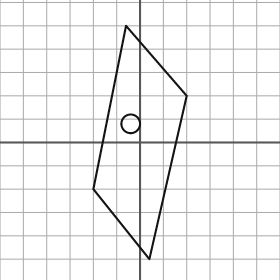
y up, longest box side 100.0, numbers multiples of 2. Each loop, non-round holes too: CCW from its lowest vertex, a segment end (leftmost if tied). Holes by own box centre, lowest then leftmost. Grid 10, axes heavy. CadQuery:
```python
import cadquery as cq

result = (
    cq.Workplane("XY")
    .moveTo(4.0, -50.0)
    .lineTo(20.0, 20.0)
    .lineTo(-6.0, 50.0)
    .lineTo(-20.0, -20.0)
    .close()
    .moveTo(-4.0, 8.0)
    .circle(4.0)
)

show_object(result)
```